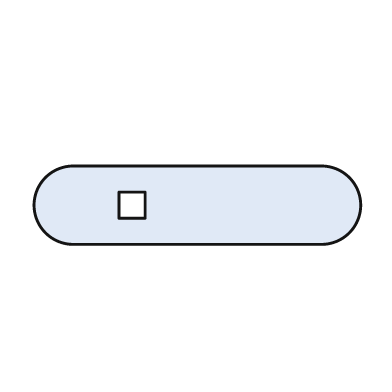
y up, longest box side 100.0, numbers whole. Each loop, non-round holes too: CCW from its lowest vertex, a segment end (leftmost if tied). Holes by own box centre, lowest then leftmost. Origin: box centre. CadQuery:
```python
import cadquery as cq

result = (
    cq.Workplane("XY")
    .moveTo(-38.0, -12.0)
    .lineTo(38.0, -12.0)
    .threePointArc((50.0, 0.0), (38.0, 12.0))
    .lineTo(-38.0, 12.0)
    .threePointArc((-50.0, 0.0), (-38.0, -12.0))
    .close()
    .moveTo(-24.0, -4.0)
    .lineTo(-16.0, -4.0)
    .lineTo(-16.0, 4.0)
    .lineTo(-24.0, 4.0)
    .close()
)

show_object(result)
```